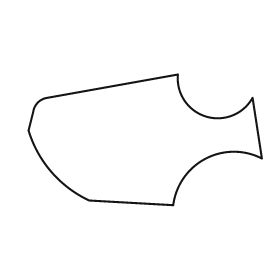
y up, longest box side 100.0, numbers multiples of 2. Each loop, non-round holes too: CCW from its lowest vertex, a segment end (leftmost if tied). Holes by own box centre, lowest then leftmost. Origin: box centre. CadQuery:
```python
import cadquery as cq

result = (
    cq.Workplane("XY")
    .moveTo(12.0, -28.0)
    .threePointArc((26.0, -8.0), (50.0, -8.0))
    .lineTo(46.0, 18.0)
    .threePointArc((26.0, 10.0), (14.0, 28.0))
    .lineTo(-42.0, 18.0)
    .threePointArc((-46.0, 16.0), (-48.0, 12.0))
    .lineTo(-50.0, 4.0)
    .threePointArc((-40.0, -14.0), (-24.0, -26.0))
    .close()
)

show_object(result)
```